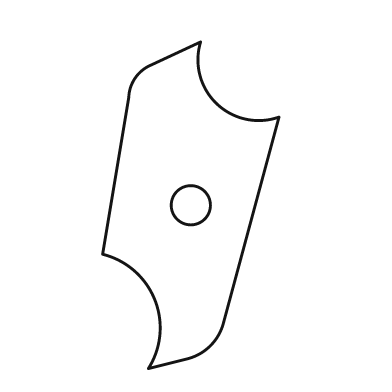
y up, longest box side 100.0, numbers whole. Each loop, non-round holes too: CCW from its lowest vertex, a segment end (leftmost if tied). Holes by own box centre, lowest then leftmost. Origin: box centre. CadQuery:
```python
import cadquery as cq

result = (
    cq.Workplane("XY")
    .moveTo(-13.0, -50.0)
    .lineTo(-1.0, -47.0)
    .threePointArc((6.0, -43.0), (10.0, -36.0))
    .lineTo(27.0, 27.0)
    .threePointArc((8.0, 31.0), (3.0, 50.0))
    .lineTo(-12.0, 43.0)
    .threePointArc((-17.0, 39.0), (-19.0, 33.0))
    .lineTo(-27.0, -15.0)
    .threePointArc((-11.0, -29.0), (-13.0, -50.0))
    .close()
    .moveTo(0.0, 0.0)
    .circle(6.0)
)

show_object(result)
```